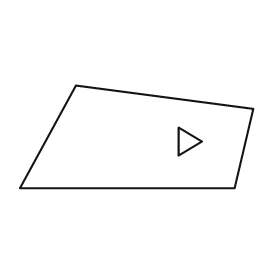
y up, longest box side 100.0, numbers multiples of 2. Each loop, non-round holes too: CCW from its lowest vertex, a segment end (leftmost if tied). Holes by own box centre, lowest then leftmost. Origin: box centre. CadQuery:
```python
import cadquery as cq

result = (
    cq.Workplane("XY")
    .moveTo(-50.0, -22.0)
    .lineTo(42.0, -22.0)
    .lineTo(50.0, 12.0)
    .lineTo(-26.0, 22.0)
    .close()
    .moveTo(18.0, -8.0)
    .lineTo(28.0, -2.0)
    .lineTo(18.0, 4.0)
    .close()
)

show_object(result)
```